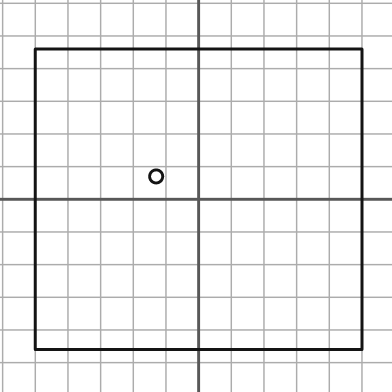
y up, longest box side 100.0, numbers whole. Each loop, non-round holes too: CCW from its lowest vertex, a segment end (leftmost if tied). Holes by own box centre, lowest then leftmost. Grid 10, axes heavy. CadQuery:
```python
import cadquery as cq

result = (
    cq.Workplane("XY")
    .moveTo(-50.0, -46.0)
    .lineTo(50.0, -46.0)
    .lineTo(50.0, 46.0)
    .lineTo(-50.0, 46.0)
    .close()
    .moveTo(-13.0, 7.0)
    .circle(2.0)
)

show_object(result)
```